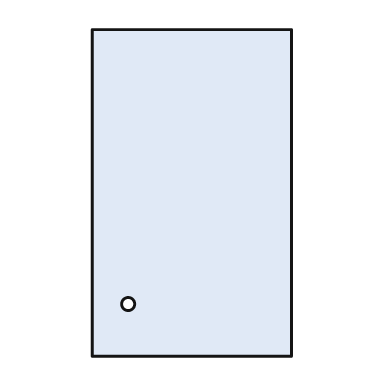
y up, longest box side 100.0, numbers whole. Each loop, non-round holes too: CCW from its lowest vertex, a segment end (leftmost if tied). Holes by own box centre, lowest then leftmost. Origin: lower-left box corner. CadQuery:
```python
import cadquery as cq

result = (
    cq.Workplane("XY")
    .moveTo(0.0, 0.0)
    .lineTo(61.0, 0.0)
    .lineTo(61.0, 100.0)
    .lineTo(0.0, 100.0)
    .close()
    .moveTo(11.0, 16.0)
    .circle(2.0)
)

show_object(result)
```